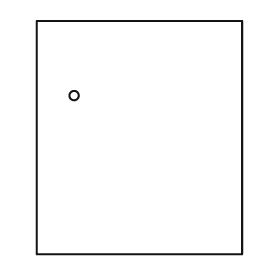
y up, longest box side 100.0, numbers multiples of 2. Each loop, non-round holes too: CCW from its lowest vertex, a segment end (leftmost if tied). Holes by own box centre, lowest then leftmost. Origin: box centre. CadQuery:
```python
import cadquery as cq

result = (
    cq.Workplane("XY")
    .moveTo(-44.0, -50.0)
    .lineTo(44.0, -50.0)
    .lineTo(44.0, 50.0)
    .lineTo(-44.0, 50.0)
    .close()
    .moveTo(-28.0, 18.0)
    .circle(2.0)
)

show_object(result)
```